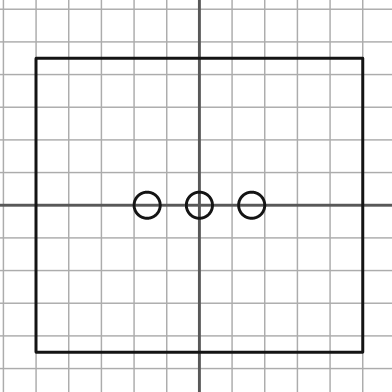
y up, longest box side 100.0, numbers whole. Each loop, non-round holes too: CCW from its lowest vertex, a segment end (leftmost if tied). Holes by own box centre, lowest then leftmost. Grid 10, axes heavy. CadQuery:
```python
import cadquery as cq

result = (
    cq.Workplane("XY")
    .moveTo(-50.0, -45.0)
    .lineTo(50.0, -45.0)
    .lineTo(50.0, 45.0)
    .lineTo(-50.0, 45.0)
    .close()
    .moveTo(-16.0, 0.0)
    .circle(4.0)
    .moveTo(0.0, 0.0)
    .circle(4.0)
    .moveTo(16.0, 0.0)
    .circle(4.0)
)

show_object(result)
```